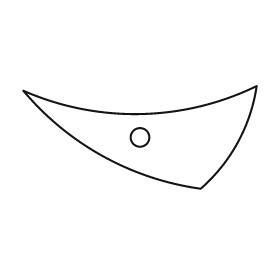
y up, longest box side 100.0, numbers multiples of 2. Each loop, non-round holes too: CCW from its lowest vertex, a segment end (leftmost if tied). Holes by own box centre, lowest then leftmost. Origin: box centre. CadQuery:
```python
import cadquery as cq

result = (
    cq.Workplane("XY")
    .moveTo(26.0, -22.0)
    .threePointArc((42.0, -2.0), (50.0, 22.0))
    .threePointArc((0.0, 10.0), (-50.0, 20.0))
    .threePointArc((-16.0, -8.0), (26.0, -22.0))
    .close()
    .moveTo(0.0, 0.0)
    .circle(4.0)
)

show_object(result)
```